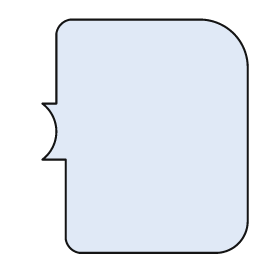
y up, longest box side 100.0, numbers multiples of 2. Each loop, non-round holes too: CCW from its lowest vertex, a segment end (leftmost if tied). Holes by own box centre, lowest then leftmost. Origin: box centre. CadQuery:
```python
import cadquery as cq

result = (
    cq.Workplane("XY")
    .moveTo(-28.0, -50.0)
    .lineTo(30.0, -50.0)
    .threePointArc((40.0, -46.0), (44.0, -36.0))
    .lineTo(44.0, 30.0)
    .threePointArc((38.0, 44.0), (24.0, 50.0))
    .lineTo(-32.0, 50.0)
    .threePointArc((-36.0, 48.0), (-38.0, 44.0))
    .lineTo(-38.0, 14.0)
    .lineTo(-44.0, 14.0)
    .threePointArc((-38.0, 2.0), (-44.0, -10.0))
    .lineTo(-34.0, -10.0)
    .lineTo(-34.0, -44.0)
    .threePointArc((-32.0, -48.0), (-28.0, -50.0))
    .close()
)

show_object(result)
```